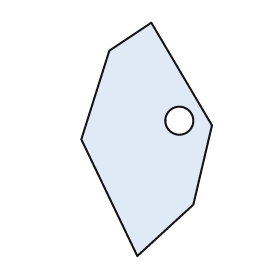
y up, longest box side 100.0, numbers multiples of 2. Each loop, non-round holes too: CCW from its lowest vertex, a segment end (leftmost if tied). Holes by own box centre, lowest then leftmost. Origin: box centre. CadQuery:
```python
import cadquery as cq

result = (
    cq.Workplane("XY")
    .moveTo(-4.0, -50.0)
    .lineTo(20.0, -28.0)
    .lineTo(28.0, 6.0)
    .lineTo(2.0, 50.0)
    .lineTo(-16.0, 38.0)
    .lineTo(-28.0, 0.0)
    .close()
    .moveTo(14.0, 8.0)
    .circle(6.0)
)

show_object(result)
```